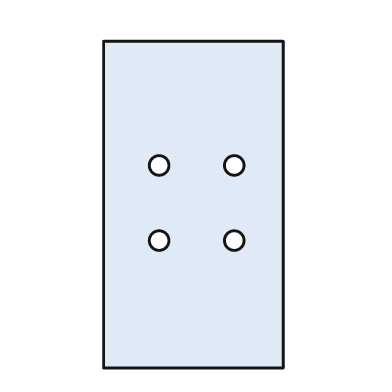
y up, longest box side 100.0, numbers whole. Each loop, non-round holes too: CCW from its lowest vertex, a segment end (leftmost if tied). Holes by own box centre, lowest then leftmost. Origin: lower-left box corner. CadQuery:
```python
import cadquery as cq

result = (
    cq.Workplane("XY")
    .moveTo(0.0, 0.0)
    .lineTo(55.0, 0.0)
    .lineTo(55.0, 100.0)
    .lineTo(0.0, 100.0)
    .close()
    .moveTo(17.0, 39.0)
    .circle(3.0)
    .moveTo(40.0, 39.0)
    .circle(3.0)
    .moveTo(17.0, 62.0)
    .circle(3.0)
    .moveTo(40.0, 62.0)
    .circle(3.0)
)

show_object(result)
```